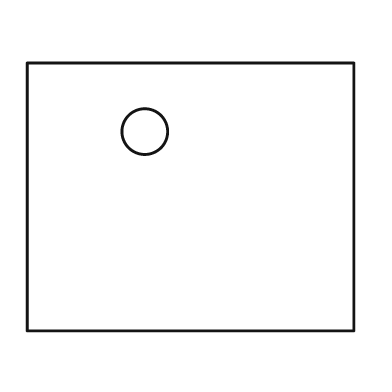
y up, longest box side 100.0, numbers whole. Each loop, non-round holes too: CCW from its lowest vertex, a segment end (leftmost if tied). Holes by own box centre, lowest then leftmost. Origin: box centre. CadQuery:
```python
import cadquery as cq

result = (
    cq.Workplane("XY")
    .moveTo(-50.0, -41.0)
    .lineTo(50.0, -41.0)
    .lineTo(50.0, 41.0)
    .lineTo(-50.0, 41.0)
    .close()
    .moveTo(-14.0, 20.0)
    .circle(7.0)
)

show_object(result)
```